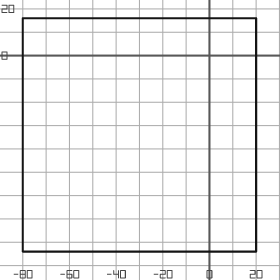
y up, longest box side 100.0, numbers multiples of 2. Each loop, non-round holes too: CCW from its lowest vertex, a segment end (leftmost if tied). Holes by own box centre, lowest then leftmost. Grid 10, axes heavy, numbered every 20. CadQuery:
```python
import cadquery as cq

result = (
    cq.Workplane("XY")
    .moveTo(-80.0, -84.0)
    .lineTo(20.0, -84.0)
    .lineTo(20.0, 16.0)
    .lineTo(-80.0, 16.0)
    .close()
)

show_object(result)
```